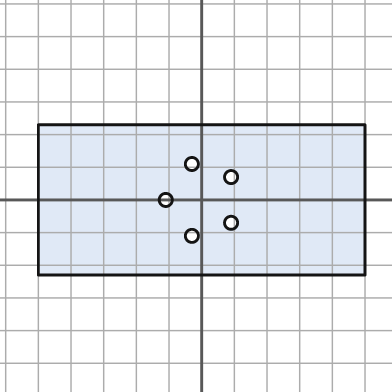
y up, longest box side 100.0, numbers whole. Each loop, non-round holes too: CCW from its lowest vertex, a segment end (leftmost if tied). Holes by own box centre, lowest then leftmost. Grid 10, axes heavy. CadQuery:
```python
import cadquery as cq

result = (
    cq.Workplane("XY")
    .moveTo(-50.0, -23.0)
    .lineTo(50.0, -23.0)
    .lineTo(50.0, 23.0)
    .lineTo(-50.0, 23.0)
    .close()
    .moveTo(-3.0, -11.0)
    .circle(2.0)
    .moveTo(9.0, -7.0)
    .circle(2.0)
    .moveTo(-11.0, 0.0)
    .circle(2.0)
    .moveTo(9.0, 7.0)
    .circle(2.0)
    .moveTo(-3.0, 11.0)
    .circle(2.0)
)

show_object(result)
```